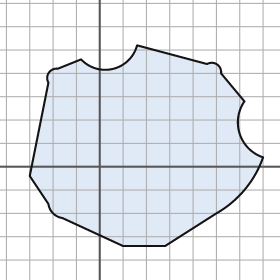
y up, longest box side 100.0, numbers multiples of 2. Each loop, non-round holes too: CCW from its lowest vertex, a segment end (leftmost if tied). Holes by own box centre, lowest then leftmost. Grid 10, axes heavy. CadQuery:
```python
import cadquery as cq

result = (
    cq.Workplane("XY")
    .moveTo(10.0, -34.0)
    .lineTo(28.0, -34.0)
    .lineTo(50.0, -20.0)
    .threePointArc((62.0, -10.0), (70.0, 4.0))
    .threePointArc((60.0, 14.0), (62.0, 28.0))
    .lineTo(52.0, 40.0)
    .threePointArc((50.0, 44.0), (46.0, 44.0))
    .lineTo(16.0, 52.0)
    .threePointArc((6.0, 42.0), (-8.0, 46.0))
    .lineTo(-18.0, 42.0)
    .threePointArc((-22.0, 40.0), (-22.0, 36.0))
    .lineTo(-30.0, -4.0)
    .lineTo(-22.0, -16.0)
    .threePointArc((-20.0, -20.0), (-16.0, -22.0))
    .close()
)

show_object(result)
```